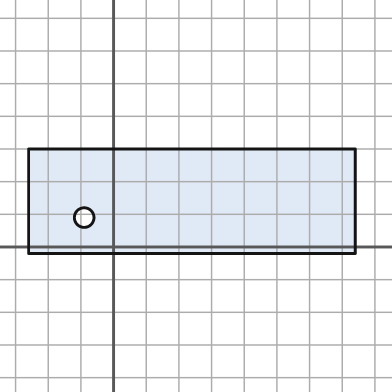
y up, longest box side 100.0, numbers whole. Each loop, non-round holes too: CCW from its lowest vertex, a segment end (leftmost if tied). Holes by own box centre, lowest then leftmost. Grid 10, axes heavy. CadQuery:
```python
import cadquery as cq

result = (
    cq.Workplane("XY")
    .moveTo(-26.0, -2.0)
    .lineTo(74.0, -2.0)
    .lineTo(74.0, 30.0)
    .lineTo(-26.0, 30.0)
    .close()
    .moveTo(-9.0, 9.0)
    .circle(3.0)
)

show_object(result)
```